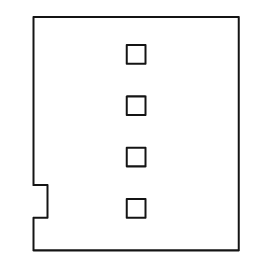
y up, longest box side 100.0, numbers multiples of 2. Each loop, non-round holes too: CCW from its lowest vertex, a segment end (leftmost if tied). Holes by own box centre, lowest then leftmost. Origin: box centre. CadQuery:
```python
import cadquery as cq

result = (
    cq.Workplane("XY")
    .moveTo(-44.0, -50.0)
    .lineTo(44.0, -50.0)
    .lineTo(44.0, 50.0)
    .lineTo(-44.0, 50.0)
    .lineTo(-44.0, -22.0)
    .lineTo(-38.0, -22.0)
    .lineTo(-38.0, -36.0)
    .lineTo(-44.0, -36.0)
    .close()
    .moveTo(-4.0, -36.0)
    .lineTo(4.0, -36.0)
    .lineTo(4.0, -28.0)
    .lineTo(-4.0, -28.0)
    .close()
    .moveTo(-4.0, -14.0)
    .lineTo(4.0, -14.0)
    .lineTo(4.0, -6.0)
    .lineTo(-4.0, -6.0)
    .close()
    .moveTo(-4.0, 8.0)
    .lineTo(4.0, 8.0)
    .lineTo(4.0, 16.0)
    .lineTo(-4.0, 16.0)
    .close()
    .moveTo(-4.0, 30.0)
    .lineTo(4.0, 30.0)
    .lineTo(4.0, 38.0)
    .lineTo(-4.0, 38.0)
    .close()
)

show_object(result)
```